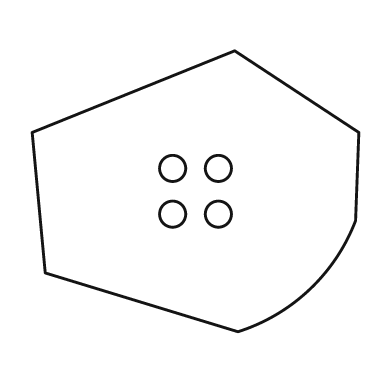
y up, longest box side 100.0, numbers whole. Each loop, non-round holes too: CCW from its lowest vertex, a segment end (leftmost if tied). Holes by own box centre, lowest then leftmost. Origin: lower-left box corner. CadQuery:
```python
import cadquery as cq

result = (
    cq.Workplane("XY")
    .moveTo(63.0, 0.0)
    .threePointArc((85.0, 13.0), (99.0, 34.0))
    .lineTo(100.0, 61.0)
    .lineTo(62.0, 86.0)
    .lineTo(0.0, 61.0)
    .lineTo(4.0, 18.0)
    .close()
    .moveTo(43.0, 36.0)
    .circle(4.0)
    .moveTo(57.0, 36.0)
    .circle(4.0)
    .moveTo(43.0, 50.0)
    .circle(4.0)
    .moveTo(57.0, 50.0)
    .circle(4.0)
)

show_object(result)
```